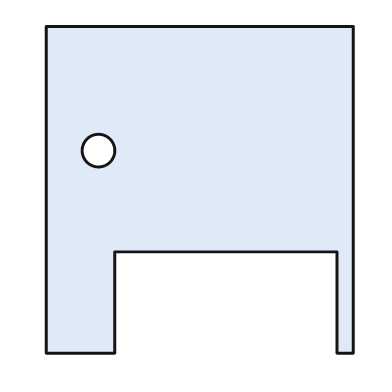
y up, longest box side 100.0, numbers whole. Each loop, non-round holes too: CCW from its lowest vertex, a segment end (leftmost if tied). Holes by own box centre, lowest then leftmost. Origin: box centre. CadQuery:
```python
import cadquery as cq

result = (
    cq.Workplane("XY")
    .moveTo(-47.0, -50.0)
    .lineTo(-26.0, -50.0)
    .lineTo(-26.0, -19.0)
    .lineTo(42.0, -19.0)
    .lineTo(42.0, -50.0)
    .lineTo(47.0, -50.0)
    .lineTo(47.0, 50.0)
    .lineTo(-47.0, 50.0)
    .close()
    .moveTo(-31.0, 12.0)
    .circle(5.0)
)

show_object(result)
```